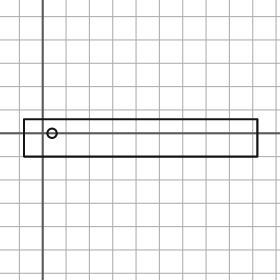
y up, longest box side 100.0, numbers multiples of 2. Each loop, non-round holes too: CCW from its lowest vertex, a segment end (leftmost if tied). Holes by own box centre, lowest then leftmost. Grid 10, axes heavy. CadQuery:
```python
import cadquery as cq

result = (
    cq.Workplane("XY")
    .moveTo(-8.0, -10.0)
    .lineTo(92.0, -10.0)
    .lineTo(92.0, 6.0)
    .lineTo(-8.0, 6.0)
    .close()
    .moveTo(4.0, 0.0)
    .circle(2.0)
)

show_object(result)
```